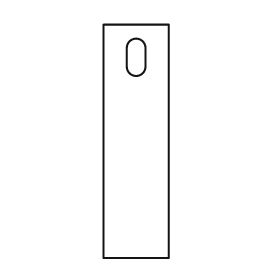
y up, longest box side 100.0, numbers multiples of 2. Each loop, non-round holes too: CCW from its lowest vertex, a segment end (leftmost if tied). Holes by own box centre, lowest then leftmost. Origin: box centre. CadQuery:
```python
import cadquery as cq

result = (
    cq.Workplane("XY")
    .moveTo(-14.0, -50.0)
    .lineTo(14.0, -50.0)
    .lineTo(14.0, 50.0)
    .lineTo(-14.0, 50.0)
    .close()
    .moveTo(-4.0, 32.0)
    .threePointArc((0.0, 28.0), (4.0, 32.0))
    .lineTo(4.0, 40.0)
    .threePointArc((0.0, 44.0), (-4.0, 40.0))
    .close()
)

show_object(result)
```